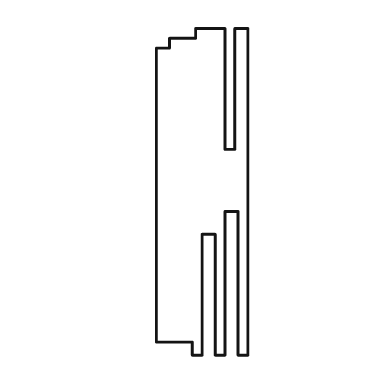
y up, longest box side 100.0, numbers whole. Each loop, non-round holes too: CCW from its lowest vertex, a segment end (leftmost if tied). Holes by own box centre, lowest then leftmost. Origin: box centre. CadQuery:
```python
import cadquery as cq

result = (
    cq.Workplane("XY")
    .moveTo(-3.0, -50.0)
    .lineTo(0.0, -50.0)
    .lineTo(0.0, -13.0)
    .lineTo(4.0, -13.0)
    .lineTo(4.0, -50.0)
    .lineTo(7.0, -50.0)
    .lineTo(7.0, -6.0)
    .lineTo(11.0, -6.0)
    .lineTo(11.0, -50.0)
    .lineTo(14.0, -50.0)
    .lineTo(14.0, 50.0)
    .lineTo(10.0, 50.0)
    .lineTo(10.0, 13.0)
    .lineTo(7.0, 13.0)
    .lineTo(7.0, 50.0)
    .lineTo(-2.0, 50.0)
    .lineTo(-2.0, 47.0)
    .lineTo(-10.0, 47.0)
    .lineTo(-10.0, 44.0)
    .lineTo(-14.0, 44.0)
    .lineTo(-14.0, -46.0)
    .lineTo(-3.0, -46.0)
    .close()
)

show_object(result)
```